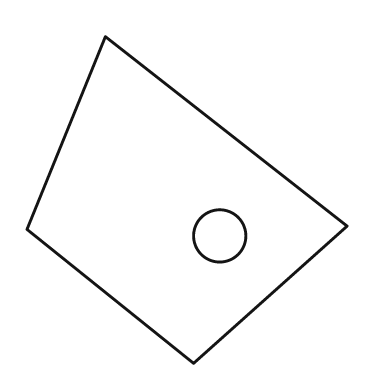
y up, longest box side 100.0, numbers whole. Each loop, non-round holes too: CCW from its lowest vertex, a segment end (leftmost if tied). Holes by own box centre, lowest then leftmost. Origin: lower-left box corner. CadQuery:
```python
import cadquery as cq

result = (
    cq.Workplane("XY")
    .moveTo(51.0, 0.0)
    .lineTo(98.0, 42.0)
    .lineTo(24.0, 100.0)
    .lineTo(0.0, 41.0)
    .close()
    .moveTo(59.0, 39.0)
    .circle(8.0)
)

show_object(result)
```